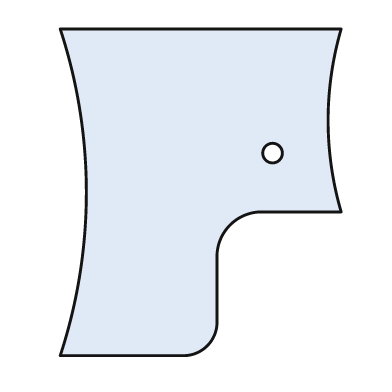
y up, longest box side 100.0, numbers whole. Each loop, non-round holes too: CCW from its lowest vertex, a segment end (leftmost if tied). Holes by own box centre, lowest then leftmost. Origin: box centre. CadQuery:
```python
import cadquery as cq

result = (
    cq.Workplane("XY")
    .moveTo(-43.0, -50.0)
    .lineTo(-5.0, -50.0)
    .threePointArc((2.0, -47.0), (5.0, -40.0))
    .lineTo(5.0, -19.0)
    .threePointArc((9.0, -10.0), (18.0, -6.0))
    .lineTo(43.0, -6.0)
    .threePointArc((39.0, 22.0), (43.0, 50.0))
    .lineTo(-43.0, 50.0)
    .threePointArc((-35.0, 0.0), (-43.0, -50.0))
    .close()
    .moveTo(22.0, 12.0)
    .circle(3.0)
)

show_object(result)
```